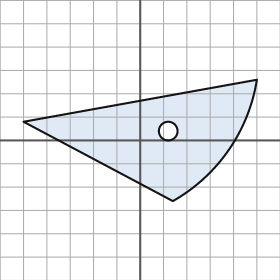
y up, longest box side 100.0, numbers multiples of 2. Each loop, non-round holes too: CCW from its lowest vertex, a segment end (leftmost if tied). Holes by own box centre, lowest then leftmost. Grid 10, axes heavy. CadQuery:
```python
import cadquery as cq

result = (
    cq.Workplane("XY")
    .moveTo(14.0, -26.0)
    .threePointArc((38.0, -4.0), (50.0, 26.0))
    .lineTo(-50.0, 8.0)
    .close()
    .moveTo(12.0, 4.0)
    .circle(4.0)
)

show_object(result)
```